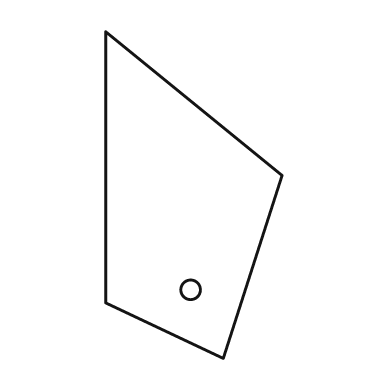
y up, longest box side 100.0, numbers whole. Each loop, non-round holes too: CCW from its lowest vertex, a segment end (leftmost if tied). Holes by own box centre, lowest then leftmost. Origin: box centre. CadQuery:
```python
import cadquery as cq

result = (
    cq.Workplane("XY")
    .moveTo(9.0, -50.0)
    .lineTo(27.0, 6.0)
    .lineTo(-27.0, 50.0)
    .lineTo(-27.0, -33.0)
    .close()
    .moveTo(-1.0, -29.0)
    .circle(3.0)
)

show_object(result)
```